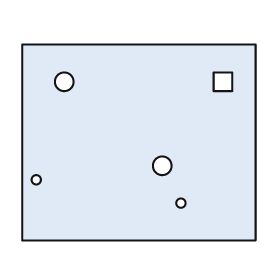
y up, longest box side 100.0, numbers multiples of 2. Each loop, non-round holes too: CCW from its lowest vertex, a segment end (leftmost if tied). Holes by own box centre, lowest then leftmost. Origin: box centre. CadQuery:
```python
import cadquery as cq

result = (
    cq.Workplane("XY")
    .moveTo(-50.0, -42.0)
    .lineTo(50.0, -42.0)
    .lineTo(50.0, 42.0)
    .lineTo(-50.0, 42.0)
    .close()
    .moveTo(18.0, -26.0)
    .circle(2.0)
    .moveTo(-44.0, -16.0)
    .circle(2.0)
    .moveTo(10.0, -10.0)
    .circle(4.0)
    .moveTo(-32.0, 26.0)
    .circle(4.0)
    .moveTo(32.0, 22.0)
    .lineTo(40.0, 22.0)
    .lineTo(40.0, 30.0)
    .lineTo(32.0, 30.0)
    .close()
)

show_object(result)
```